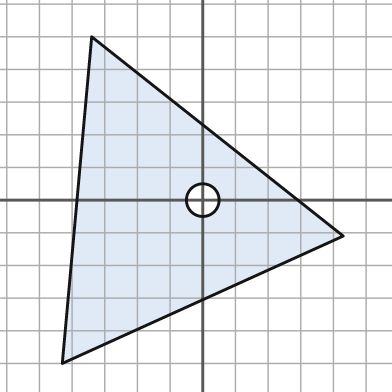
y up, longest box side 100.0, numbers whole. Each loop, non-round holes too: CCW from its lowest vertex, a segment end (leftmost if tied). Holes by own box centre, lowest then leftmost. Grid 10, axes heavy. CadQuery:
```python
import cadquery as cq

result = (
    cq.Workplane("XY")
    .moveTo(-43.0, -50.0)
    .lineTo(43.0, -11.0)
    .lineTo(-34.0, 50.0)
    .close()
    .moveTo(0.0, 0.0)
    .circle(5.0)
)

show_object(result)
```